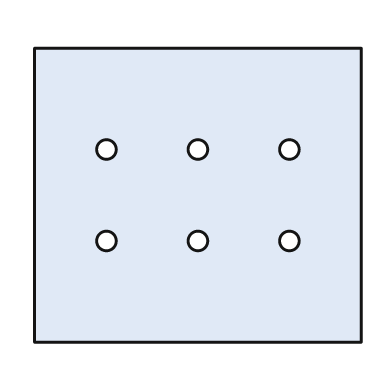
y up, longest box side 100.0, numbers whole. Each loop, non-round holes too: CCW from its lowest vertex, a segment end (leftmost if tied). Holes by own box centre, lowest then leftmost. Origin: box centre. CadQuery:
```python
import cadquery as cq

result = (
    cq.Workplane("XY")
    .moveTo(-50.0, -45.0)
    .lineTo(50.0, -45.0)
    .lineTo(50.0, 45.0)
    .lineTo(-50.0, 45.0)
    .close()
    .moveTo(-28.0, -14.0)
    .circle(3.0)
    .moveTo(0.0, -14.0)
    .circle(3.0)
    .moveTo(28.0, -14.0)
    .circle(3.0)
    .moveTo(-28.0, 14.0)
    .circle(3.0)
    .moveTo(0.0, 14.0)
    .circle(3.0)
    .moveTo(28.0, 14.0)
    .circle(3.0)
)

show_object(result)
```